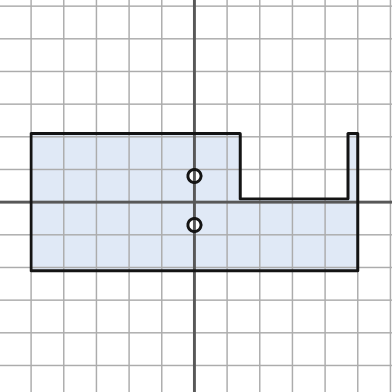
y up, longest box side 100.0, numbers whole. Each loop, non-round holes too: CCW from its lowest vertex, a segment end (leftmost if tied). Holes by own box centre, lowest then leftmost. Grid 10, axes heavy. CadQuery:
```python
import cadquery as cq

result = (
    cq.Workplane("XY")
    .moveTo(-50.0, -21.0)
    .lineTo(50.0, -21.0)
    .lineTo(50.0, 21.0)
    .lineTo(47.0, 21.0)
    .lineTo(47.0, 1.0)
    .lineTo(14.0, 1.0)
    .lineTo(14.0, 21.0)
    .lineTo(-50.0, 21.0)
    .close()
    .moveTo(0.0, -7.0)
    .circle(2.0)
    .moveTo(0.0, 8.0)
    .circle(2.0)
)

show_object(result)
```